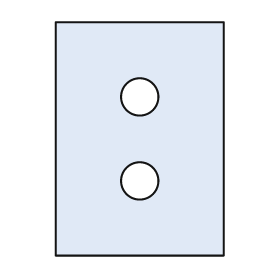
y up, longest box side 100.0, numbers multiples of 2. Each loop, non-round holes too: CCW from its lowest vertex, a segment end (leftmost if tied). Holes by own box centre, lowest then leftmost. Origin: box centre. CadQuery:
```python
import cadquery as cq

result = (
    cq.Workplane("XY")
    .moveTo(-36.0, -50.0)
    .lineTo(36.0, -50.0)
    .lineTo(36.0, 50.0)
    .lineTo(-36.0, 50.0)
    .close()
    .moveTo(0.0, -18.0)
    .circle(8.0)
    .moveTo(0.0, 18.0)
    .circle(8.0)
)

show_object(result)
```